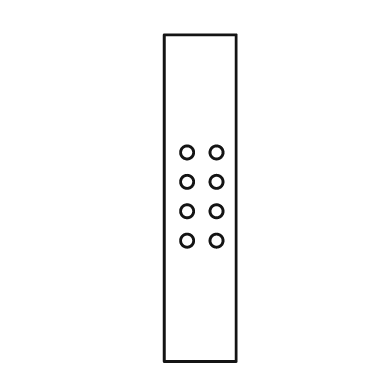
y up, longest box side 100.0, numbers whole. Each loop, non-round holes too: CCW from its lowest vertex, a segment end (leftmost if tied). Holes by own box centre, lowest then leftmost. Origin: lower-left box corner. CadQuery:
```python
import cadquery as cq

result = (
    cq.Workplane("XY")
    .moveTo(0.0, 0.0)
    .lineTo(22.0, 0.0)
    .lineTo(22.0, 100.0)
    .lineTo(0.0, 100.0)
    .close()
    .moveTo(7.0, 37.0)
    .circle(2.0)
    .moveTo(16.0, 37.0)
    .circle(2.0)
    .moveTo(7.0, 46.0)
    .circle(2.0)
    .moveTo(16.0, 46.0)
    .circle(2.0)
    .moveTo(7.0, 55.0)
    .circle(2.0)
    .moveTo(16.0, 55.0)
    .circle(2.0)
    .moveTo(7.0, 64.0)
    .circle(2.0)
    .moveTo(16.0, 64.0)
    .circle(2.0)
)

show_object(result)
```